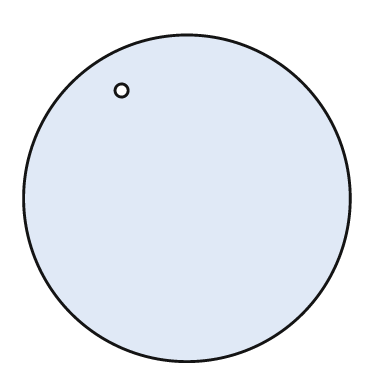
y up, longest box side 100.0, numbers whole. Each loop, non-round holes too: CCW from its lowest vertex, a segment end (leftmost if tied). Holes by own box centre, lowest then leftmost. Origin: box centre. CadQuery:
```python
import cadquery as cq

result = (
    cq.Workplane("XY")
    .moveTo(0.0, 0.0)
    .circle(50.0)
    .moveTo(-20.0, 33.0)
    .circle(2.0)
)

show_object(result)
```